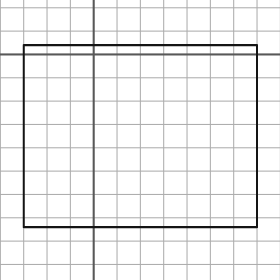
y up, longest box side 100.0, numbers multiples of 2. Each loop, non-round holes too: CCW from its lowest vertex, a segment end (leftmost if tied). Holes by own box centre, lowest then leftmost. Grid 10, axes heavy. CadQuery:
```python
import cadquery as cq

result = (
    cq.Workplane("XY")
    .moveTo(-30.0, -74.0)
    .lineTo(70.0, -74.0)
    .lineTo(70.0, 4.0)
    .lineTo(-30.0, 4.0)
    .close()
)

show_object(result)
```